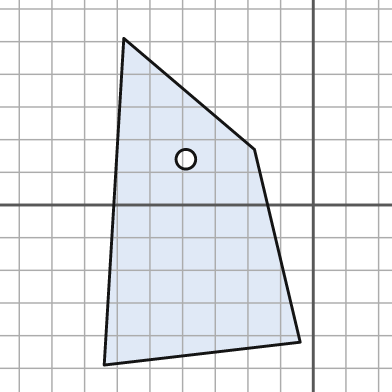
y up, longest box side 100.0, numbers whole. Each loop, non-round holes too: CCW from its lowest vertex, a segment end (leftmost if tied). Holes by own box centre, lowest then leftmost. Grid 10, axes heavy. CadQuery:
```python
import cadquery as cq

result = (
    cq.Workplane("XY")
    .moveTo(-64.0, -49.0)
    .lineTo(-4.0, -42.0)
    .lineTo(-18.0, 17.0)
    .lineTo(-58.0, 51.0)
    .close()
    .moveTo(-39.0, 14.0)
    .circle(3.0)
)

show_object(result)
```